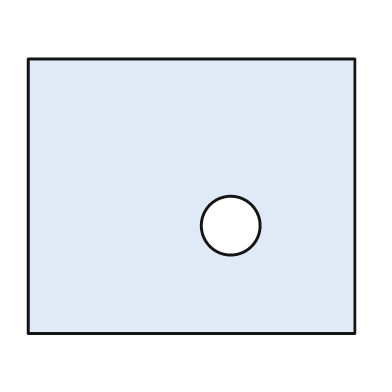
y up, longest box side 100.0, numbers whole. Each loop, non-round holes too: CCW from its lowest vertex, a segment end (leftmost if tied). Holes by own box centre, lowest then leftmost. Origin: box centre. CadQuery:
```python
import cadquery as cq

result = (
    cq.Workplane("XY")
    .moveTo(-50.0, -42.0)
    .lineTo(50.0, -42.0)
    .lineTo(50.0, 42.0)
    .lineTo(-50.0, 42.0)
    .close()
    .moveTo(12.0, -9.0)
    .circle(9.0)
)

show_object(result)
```